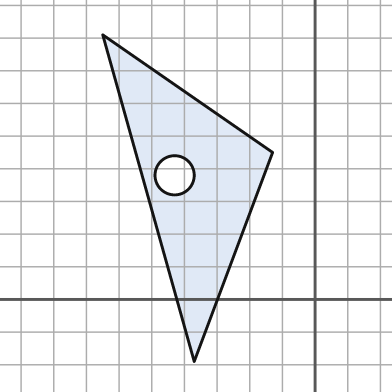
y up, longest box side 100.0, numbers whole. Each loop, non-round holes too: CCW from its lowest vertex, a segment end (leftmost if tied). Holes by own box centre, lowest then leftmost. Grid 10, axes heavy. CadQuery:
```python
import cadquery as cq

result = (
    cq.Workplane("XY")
    .moveTo(-37.0, -19.0)
    .lineTo(-13.0, 45.0)
    .lineTo(-65.0, 81.0)
    .close()
    .moveTo(-43.0, 38.0)
    .circle(6.0)
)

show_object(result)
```